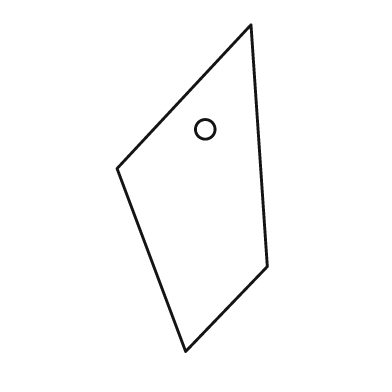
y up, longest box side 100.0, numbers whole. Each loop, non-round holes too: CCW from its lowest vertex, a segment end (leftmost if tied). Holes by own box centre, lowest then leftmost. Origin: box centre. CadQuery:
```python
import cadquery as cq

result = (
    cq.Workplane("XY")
    .moveTo(-2.0, -50.0)
    .lineTo(23.0, -24.0)
    .lineTo(18.0, 50.0)
    .lineTo(-23.0, 6.0)
    .close()
    .moveTo(4.0, 18.0)
    .circle(3.0)
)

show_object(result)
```